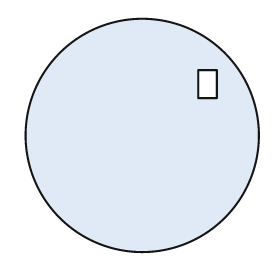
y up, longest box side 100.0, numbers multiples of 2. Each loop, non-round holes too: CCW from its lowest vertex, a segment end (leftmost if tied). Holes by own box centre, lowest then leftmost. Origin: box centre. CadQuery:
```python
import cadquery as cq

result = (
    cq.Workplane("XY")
    .moveTo(0.0, 0.0)
    .circle(50.0)
    .moveTo(24.0, 16.0)
    .lineTo(32.0, 16.0)
    .lineTo(32.0, 28.0)
    .lineTo(24.0, 28.0)
    .close()
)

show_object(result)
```